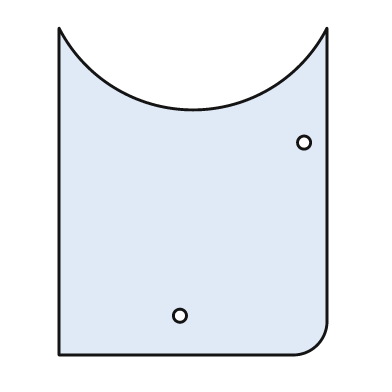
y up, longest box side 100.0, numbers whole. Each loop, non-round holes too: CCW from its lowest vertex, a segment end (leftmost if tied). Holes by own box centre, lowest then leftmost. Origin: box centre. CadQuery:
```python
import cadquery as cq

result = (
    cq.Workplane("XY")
    .moveTo(-41.0, -50.0)
    .lineTo(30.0, -50.0)
    .threePointArc((38.0, -47.0), (41.0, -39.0))
    .lineTo(41.0, 50.0)
    .threePointArc((0.0, 25.0), (-41.0, 50.0))
    .close()
    .moveTo(-4.0, -38.0)
    .circle(2.0)
    .moveTo(34.0, 15.0)
    .circle(2.0)
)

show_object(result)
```